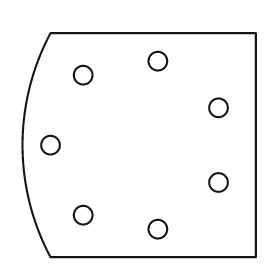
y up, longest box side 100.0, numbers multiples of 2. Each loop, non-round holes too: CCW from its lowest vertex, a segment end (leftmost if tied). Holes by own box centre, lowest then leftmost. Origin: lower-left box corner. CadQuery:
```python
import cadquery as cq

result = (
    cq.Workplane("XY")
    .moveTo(12.0, 0.0)
    .lineTo(100.0, 0.0)
    .lineTo(100.0, 96.0)
    .lineTo(12.0, 96.0)
    .threePointArc((0.0, 48.0), (12.0, 0.0))
    .close()
    .moveTo(58.0, 12.0)
    .circle(4.0)
    .moveTo(26.0, 18.0)
    .circle(4.0)
    .moveTo(84.0, 32.0)
    .circle(4.0)
    .moveTo(12.0, 48.0)
    .circle(4.0)
    .moveTo(84.0, 64.0)
    .circle(4.0)
    .moveTo(26.0, 78.0)
    .circle(4.0)
    .moveTo(58.0, 84.0)
    .circle(4.0)
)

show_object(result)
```